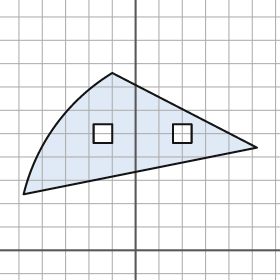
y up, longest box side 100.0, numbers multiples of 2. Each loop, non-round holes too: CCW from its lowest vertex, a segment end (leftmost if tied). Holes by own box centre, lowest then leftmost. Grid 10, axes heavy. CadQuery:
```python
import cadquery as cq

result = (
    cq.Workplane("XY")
    .moveTo(-48.0, 24.0)
    .lineTo(52.0, 44.0)
    .lineTo(-10.0, 76.0)
    .threePointArc((-34.0, 54.0), (-48.0, 24.0))
    .close()
    .moveTo(-18.0, 46.0)
    .lineTo(-10.0, 46.0)
    .lineTo(-10.0, 54.0)
    .lineTo(-18.0, 54.0)
    .close()
    .moveTo(16.0, 46.0)
    .lineTo(24.0, 46.0)
    .lineTo(24.0, 54.0)
    .lineTo(16.0, 54.0)
    .close()
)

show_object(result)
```